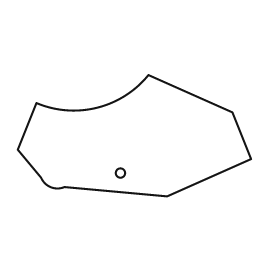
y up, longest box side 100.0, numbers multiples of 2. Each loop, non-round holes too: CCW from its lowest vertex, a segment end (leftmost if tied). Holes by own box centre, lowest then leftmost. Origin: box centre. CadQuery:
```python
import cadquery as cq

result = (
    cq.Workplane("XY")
    .moveTo(14.0, -26.0)
    .lineTo(50.0, -10.0)
    .lineTo(42.0, 10.0)
    .lineTo(6.0, 26.0)
    .threePointArc((-16.0, 12.0), (-42.0, 14.0))
    .lineTo(-50.0, -6.0)
    .lineTo(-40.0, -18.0)
    .threePointArc((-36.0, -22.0), (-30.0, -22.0))
    .close()
    .moveTo(-6.0, -16.0)
    .circle(2.0)
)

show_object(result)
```